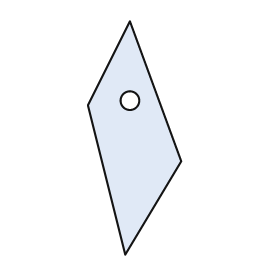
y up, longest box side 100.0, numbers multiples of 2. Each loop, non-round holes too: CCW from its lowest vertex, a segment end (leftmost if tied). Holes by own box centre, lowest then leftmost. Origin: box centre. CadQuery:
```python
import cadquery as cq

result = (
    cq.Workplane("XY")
    .moveTo(-4.0, -50.0)
    .lineTo(20.0, -10.0)
    .lineTo(-2.0, 50.0)
    .lineTo(-20.0, 14.0)
    .close()
    .moveTo(-2.0, 16.0)
    .circle(4.0)
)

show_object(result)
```